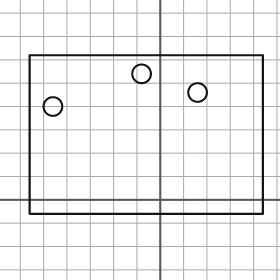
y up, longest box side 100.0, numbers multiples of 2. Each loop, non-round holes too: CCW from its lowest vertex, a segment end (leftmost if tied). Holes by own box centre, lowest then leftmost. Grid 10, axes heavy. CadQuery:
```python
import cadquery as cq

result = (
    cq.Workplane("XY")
    .moveTo(-56.0, -6.0)
    .lineTo(44.0, -6.0)
    .lineTo(44.0, 62.0)
    .lineTo(-56.0, 62.0)
    .close()
    .moveTo(-46.0, 40.0)
    .circle(4.0)
    .moveTo(16.0, 46.0)
    .circle(4.0)
    .moveTo(-8.0, 54.0)
    .circle(4.0)
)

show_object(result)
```